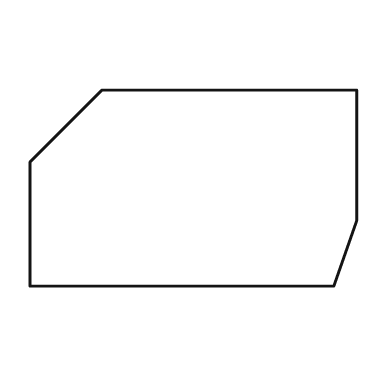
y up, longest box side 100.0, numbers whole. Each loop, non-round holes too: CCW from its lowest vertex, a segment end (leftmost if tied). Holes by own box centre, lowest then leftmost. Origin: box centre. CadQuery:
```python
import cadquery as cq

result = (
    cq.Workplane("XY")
    .moveTo(-50.0, -30.0)
    .lineTo(43.0, -30.0)
    .lineTo(50.0, -10.0)
    .lineTo(50.0, 30.0)
    .lineTo(-28.0, 30.0)
    .lineTo(-50.0, 8.0)
    .close()
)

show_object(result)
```